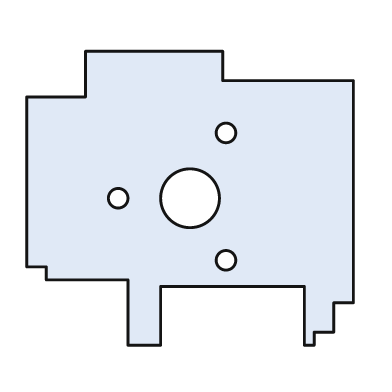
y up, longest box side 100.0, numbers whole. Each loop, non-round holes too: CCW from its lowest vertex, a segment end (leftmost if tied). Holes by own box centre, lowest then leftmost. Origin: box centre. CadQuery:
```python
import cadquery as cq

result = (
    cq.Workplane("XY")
    .moveTo(-19.0, -45.0)
    .lineTo(-9.0, -45.0)
    .lineTo(-9.0, -27.0)
    .lineTo(35.0, -27.0)
    .lineTo(35.0, -45.0)
    .lineTo(38.0, -45.0)
    .lineTo(38.0, -41.0)
    .lineTo(44.0, -41.0)
    .lineTo(44.0, -32.0)
    .lineTo(50.0, -32.0)
    .lineTo(50.0, 36.0)
    .lineTo(10.0, 36.0)
    .lineTo(10.0, 45.0)
    .lineTo(-32.0, 45.0)
    .lineTo(-32.0, 31.0)
    .lineTo(-50.0, 31.0)
    .lineTo(-50.0, -21.0)
    .lineTo(-44.0, -21.0)
    .lineTo(-44.0, -25.0)
    .lineTo(-19.0, -25.0)
    .close()
    .moveTo(11.0, -19.0)
    .circle(3.0)
    .moveTo(-22.0, 0.0)
    .circle(3.0)
    .moveTo(0.0, 0.0)
    .circle(9.0)
    .moveTo(11.0, 20.0)
    .circle(3.0)
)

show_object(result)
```